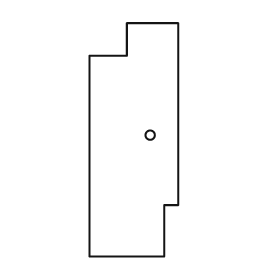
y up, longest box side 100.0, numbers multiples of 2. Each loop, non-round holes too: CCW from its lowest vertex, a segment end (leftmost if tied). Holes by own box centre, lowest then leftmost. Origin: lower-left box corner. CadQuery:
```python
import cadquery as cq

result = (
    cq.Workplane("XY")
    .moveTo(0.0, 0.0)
    .lineTo(32.0, 0.0)
    .lineTo(32.0, 22.0)
    .lineTo(38.0, 22.0)
    .lineTo(38.0, 100.0)
    .lineTo(16.0, 100.0)
    .lineTo(16.0, 86.0)
    .lineTo(0.0, 86.0)
    .close()
    .moveTo(26.0, 52.0)
    .circle(2.0)
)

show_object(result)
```